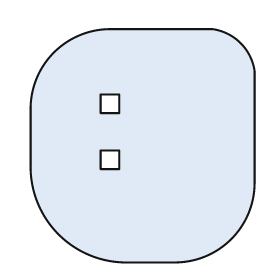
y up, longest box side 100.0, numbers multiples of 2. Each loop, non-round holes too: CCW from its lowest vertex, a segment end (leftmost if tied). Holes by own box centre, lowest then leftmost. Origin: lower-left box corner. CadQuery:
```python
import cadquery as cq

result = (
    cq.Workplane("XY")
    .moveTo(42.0, 0.0)
    .lineTo(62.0, 0.0)
    .threePointArc((86.0, 10.0), (96.0, 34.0))
    .lineTo(96.0, 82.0)
    .threePointArc((90.0, 94.0), (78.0, 100.0))
    .lineTo(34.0, 100.0)
    .threePointArc((10.0, 90.0), (0.0, 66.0))
    .lineTo(0.0, 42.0)
    .threePointArc((12.0, 12.0), (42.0, 0.0))
    .close()
    .moveTo(30.0, 40.0)
    .lineTo(38.0, 40.0)
    .lineTo(38.0, 48.0)
    .lineTo(30.0, 48.0)
    .close()
    .moveTo(30.0, 64.0)
    .lineTo(38.0, 64.0)
    .lineTo(38.0, 72.0)
    .lineTo(30.0, 72.0)
    .close()
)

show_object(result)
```